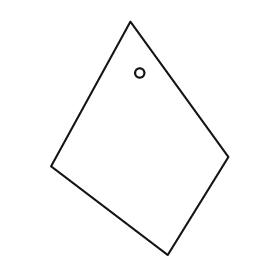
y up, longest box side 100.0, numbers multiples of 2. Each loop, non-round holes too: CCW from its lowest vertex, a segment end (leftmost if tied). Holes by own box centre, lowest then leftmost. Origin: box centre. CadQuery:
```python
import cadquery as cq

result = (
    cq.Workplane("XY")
    .moveTo(12.0, -50.0)
    .lineTo(38.0, -8.0)
    .lineTo(-4.0, 50.0)
    .lineTo(-38.0, -12.0)
    .close()
    .moveTo(0.0, 28.0)
    .circle(2.0)
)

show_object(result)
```